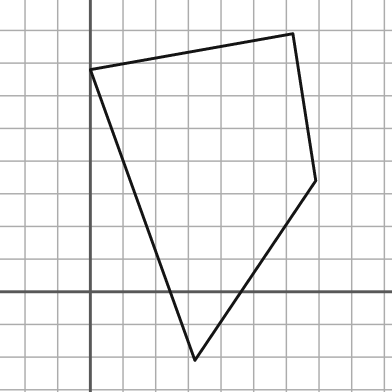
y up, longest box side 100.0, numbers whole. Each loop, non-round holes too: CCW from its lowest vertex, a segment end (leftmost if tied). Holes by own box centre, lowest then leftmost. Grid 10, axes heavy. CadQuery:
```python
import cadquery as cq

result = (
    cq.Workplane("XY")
    .moveTo(32.0, -21.0)
    .lineTo(69.0, 34.0)
    .lineTo(62.0, 79.0)
    .lineTo(0.0, 68.0)
    .close()
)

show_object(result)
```